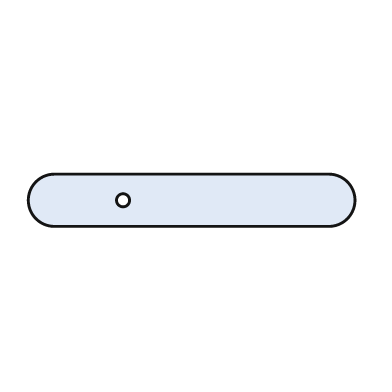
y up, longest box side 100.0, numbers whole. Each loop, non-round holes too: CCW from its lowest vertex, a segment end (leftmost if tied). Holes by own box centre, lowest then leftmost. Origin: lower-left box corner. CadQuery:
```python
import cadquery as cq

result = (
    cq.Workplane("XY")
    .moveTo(8.0, 0.0)
    .lineTo(92.0, 0.0)
    .threePointArc((100.0, 8.0), (92.0, 16.0))
    .lineTo(8.0, 16.0)
    .threePointArc((0.0, 8.0), (8.0, 0.0))
    .close()
    .moveTo(29.0, 8.0)
    .circle(2.0)
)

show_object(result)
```